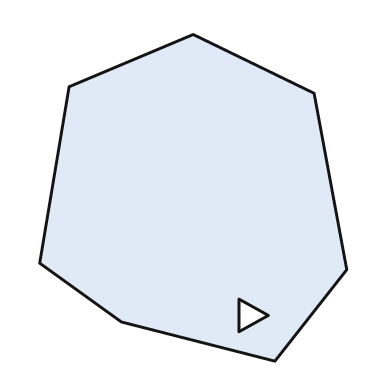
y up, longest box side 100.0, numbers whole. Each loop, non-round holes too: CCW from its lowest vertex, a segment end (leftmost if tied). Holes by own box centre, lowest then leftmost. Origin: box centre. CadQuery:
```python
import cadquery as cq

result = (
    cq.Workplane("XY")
    .moveTo(25.0, -50.0)
    .lineTo(47.0, -22.0)
    .lineTo(37.0, 32.0)
    .lineTo(0.0, 50.0)
    .lineTo(-38.0, 34.0)
    .lineTo(-47.0, -20.0)
    .lineTo(-22.0, -38.0)
    .close()
    .moveTo(14.0, -41.0)
    .lineTo(23.0, -36.0)
    .lineTo(14.0, -31.0)
    .close()
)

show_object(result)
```